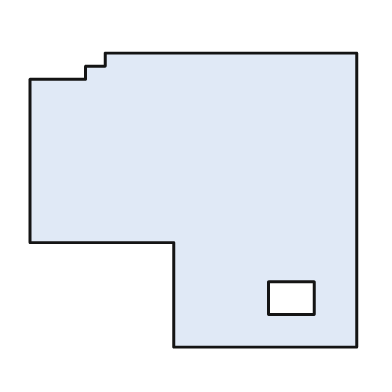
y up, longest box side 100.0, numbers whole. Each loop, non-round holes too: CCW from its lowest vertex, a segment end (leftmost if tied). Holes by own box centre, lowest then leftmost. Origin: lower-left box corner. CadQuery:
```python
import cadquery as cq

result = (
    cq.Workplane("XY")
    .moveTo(44.0, 0.0)
    .lineTo(100.0, 0.0)
    .lineTo(100.0, 90.0)
    .lineTo(23.0, 90.0)
    .lineTo(23.0, 86.0)
    .lineTo(17.0, 86.0)
    .lineTo(17.0, 82.0)
    .lineTo(0.0, 82.0)
    .lineTo(0.0, 32.0)
    .lineTo(44.0, 32.0)
    .close()
    .moveTo(73.0, 10.0)
    .lineTo(87.0, 10.0)
    .lineTo(87.0, 20.0)
    .lineTo(73.0, 20.0)
    .close()
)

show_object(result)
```